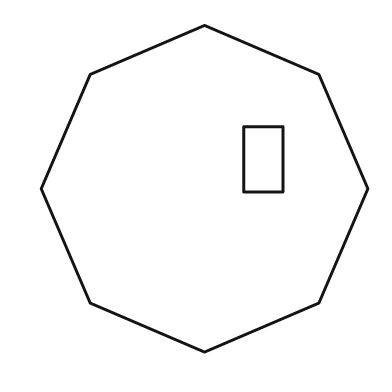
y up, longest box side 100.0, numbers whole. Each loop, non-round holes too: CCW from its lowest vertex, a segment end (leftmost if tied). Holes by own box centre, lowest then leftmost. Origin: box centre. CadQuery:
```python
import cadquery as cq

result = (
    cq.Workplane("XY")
    .moveTo(0.0, -50.0)
    .lineTo(35.0, -35.0)
    .lineTo(50.0, 0.0)
    .lineTo(35.0, 35.0)
    .lineTo(0.0, 50.0)
    .lineTo(-35.0, 35.0)
    .lineTo(-50.0, 0.0)
    .lineTo(-35.0, -35.0)
    .close()
    .moveTo(12.0, -1.0)
    .lineTo(24.0, -1.0)
    .lineTo(24.0, 19.0)
    .lineTo(12.0, 19.0)
    .close()
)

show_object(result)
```